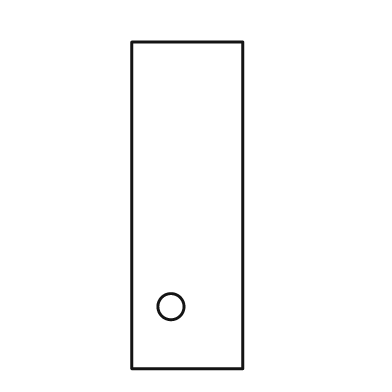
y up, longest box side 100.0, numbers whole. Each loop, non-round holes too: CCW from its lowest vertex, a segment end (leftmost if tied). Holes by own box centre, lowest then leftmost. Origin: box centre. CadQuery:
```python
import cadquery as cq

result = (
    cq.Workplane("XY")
    .moveTo(-17.0, -50.0)
    .lineTo(17.0, -50.0)
    .lineTo(17.0, 50.0)
    .lineTo(-17.0, 50.0)
    .close()
    .moveTo(-5.0, -31.0)
    .circle(4.0)
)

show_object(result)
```